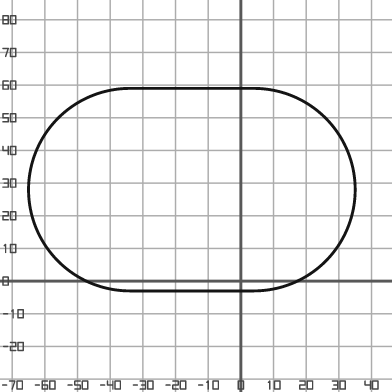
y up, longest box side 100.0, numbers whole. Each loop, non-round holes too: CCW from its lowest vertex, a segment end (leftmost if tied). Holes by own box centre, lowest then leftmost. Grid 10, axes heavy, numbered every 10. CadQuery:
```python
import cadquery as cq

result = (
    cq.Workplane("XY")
    .moveTo(-34.0, -3.0)
    .lineTo(4.0, -3.0)
    .threePointArc((35.0, 28.0), (4.0, 59.0))
    .lineTo(-34.0, 59.0)
    .threePointArc((-65.0, 28.0), (-34.0, -3.0))
    .close()
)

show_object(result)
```